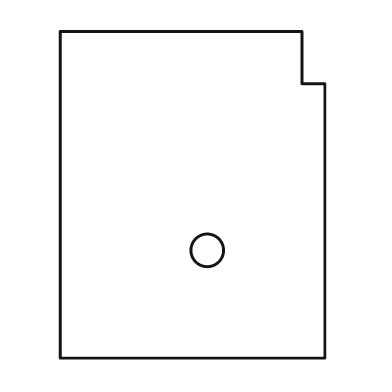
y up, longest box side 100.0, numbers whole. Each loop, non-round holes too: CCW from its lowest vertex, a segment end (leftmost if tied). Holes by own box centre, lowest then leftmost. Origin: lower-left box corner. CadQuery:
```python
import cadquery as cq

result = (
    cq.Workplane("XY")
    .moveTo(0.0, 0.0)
    .lineTo(81.0, 0.0)
    .lineTo(81.0, 84.0)
    .lineTo(74.0, 84.0)
    .lineTo(74.0, 100.0)
    .lineTo(0.0, 100.0)
    .close()
    .moveTo(45.0, 33.0)
    .circle(5.0)
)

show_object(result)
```